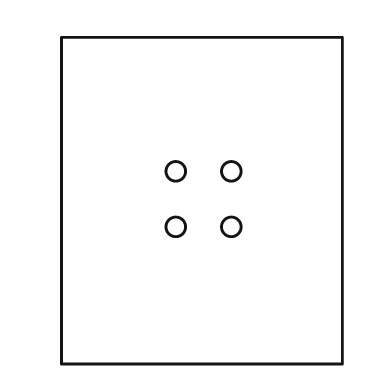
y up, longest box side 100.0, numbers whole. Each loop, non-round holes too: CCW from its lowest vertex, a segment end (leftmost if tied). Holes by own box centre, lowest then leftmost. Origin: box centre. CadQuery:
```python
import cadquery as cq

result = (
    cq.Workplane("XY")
    .moveTo(-43.0, -50.0)
    .lineTo(43.0, -50.0)
    .lineTo(43.0, 50.0)
    .lineTo(-43.0, 50.0)
    .close()
    .moveTo(-8.0, -8.0)
    .circle(3.0)
    .moveTo(9.0, -8.0)
    .circle(3.0)
    .moveTo(-8.0, 9.0)
    .circle(3.0)
    .moveTo(9.0, 9.0)
    .circle(3.0)
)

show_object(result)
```